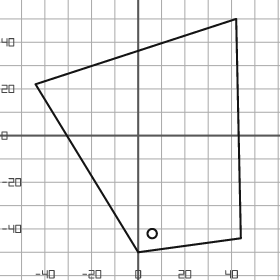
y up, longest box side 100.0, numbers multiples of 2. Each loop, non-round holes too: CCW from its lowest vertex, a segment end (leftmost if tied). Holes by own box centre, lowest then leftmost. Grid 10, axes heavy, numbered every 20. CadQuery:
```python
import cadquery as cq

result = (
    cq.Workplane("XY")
    .moveTo(0.0, -50.0)
    .lineTo(44.0, -44.0)
    .lineTo(42.0, 50.0)
    .lineTo(-44.0, 22.0)
    .close()
    .moveTo(6.0, -42.0)
    .circle(2.0)
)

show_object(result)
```